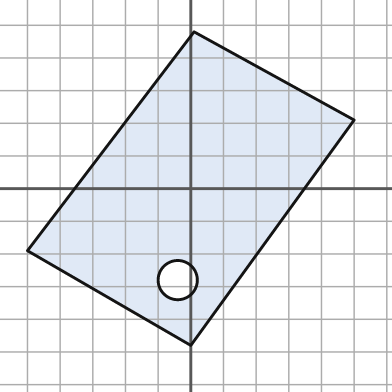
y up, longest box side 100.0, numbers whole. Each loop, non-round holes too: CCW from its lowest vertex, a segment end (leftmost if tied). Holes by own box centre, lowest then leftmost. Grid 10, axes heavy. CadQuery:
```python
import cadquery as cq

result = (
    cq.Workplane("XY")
    .moveTo(0.0, -48.0)
    .lineTo(50.0, 21.0)
    .lineTo(1.0, 48.0)
    .lineTo(-50.0, -19.0)
    .close()
    .moveTo(-4.0, -28.0)
    .circle(6.0)
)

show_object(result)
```